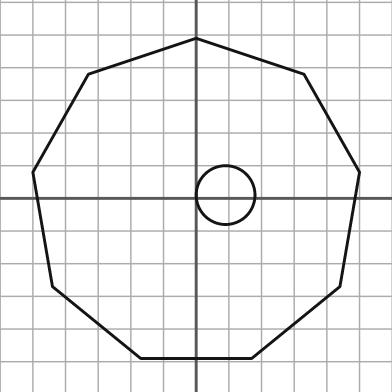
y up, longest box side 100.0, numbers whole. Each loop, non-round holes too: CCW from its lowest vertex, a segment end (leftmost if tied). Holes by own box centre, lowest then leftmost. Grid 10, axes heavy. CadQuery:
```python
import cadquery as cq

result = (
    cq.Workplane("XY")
    .moveTo(-17.0, -49.0)
    .lineTo(17.0, -49.0)
    .lineTo(44.0, -27.0)
    .lineTo(50.0, 8.0)
    .lineTo(33.0, 38.0)
    .lineTo(0.0, 49.0)
    .lineTo(-33.0, 38.0)
    .lineTo(-50.0, 8.0)
    .lineTo(-44.0, -27.0)
    .close()
    .moveTo(9.0, 1.0)
    .circle(9.0)
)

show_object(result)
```